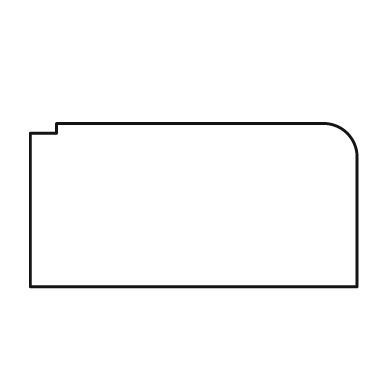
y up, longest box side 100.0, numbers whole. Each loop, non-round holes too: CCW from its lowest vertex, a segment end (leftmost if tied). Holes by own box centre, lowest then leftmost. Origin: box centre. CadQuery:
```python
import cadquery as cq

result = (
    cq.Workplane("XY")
    .moveTo(-50.0, -25.0)
    .lineTo(50.0, -25.0)
    .lineTo(50.0, 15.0)
    .threePointArc((47.0, 22.0), (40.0, 25.0))
    .lineTo(-42.0, 25.0)
    .lineTo(-42.0, 22.0)
    .lineTo(-50.0, 22.0)
    .close()
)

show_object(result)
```